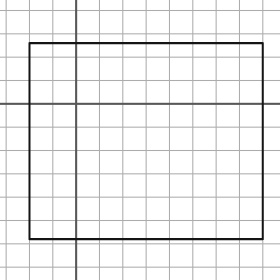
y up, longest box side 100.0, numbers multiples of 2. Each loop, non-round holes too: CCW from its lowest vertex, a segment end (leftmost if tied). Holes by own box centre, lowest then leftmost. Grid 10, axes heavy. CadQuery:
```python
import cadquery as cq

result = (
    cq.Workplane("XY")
    .moveTo(-20.0, -58.0)
    .lineTo(80.0, -58.0)
    .lineTo(80.0, 26.0)
    .lineTo(-20.0, 26.0)
    .close()
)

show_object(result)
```